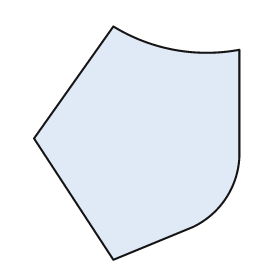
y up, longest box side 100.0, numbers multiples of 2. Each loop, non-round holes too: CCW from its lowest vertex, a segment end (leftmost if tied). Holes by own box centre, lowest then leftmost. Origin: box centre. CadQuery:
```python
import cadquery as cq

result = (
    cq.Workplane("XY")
    .moveTo(-10.0, -50.0)
    .lineTo(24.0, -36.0)
    .threePointArc((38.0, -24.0), (44.0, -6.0))
    .lineTo(44.0, 40.0)
    .threePointArc((16.0, 40.0), (-10.0, 50.0))
    .lineTo(-44.0, 2.0)
    .close()
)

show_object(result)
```